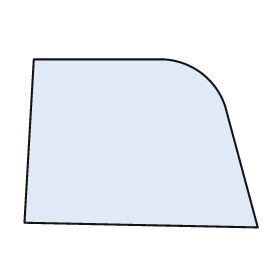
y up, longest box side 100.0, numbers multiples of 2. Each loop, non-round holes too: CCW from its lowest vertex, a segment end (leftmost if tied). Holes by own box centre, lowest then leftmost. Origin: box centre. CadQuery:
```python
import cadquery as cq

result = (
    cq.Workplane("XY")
    .moveTo(50.0, -36.0)
    .lineTo(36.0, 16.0)
    .threePointArc((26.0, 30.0), (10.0, 36.0))
    .lineTo(-46.0, 36.0)
    .lineTo(-50.0, -34.0)
    .close()
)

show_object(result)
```